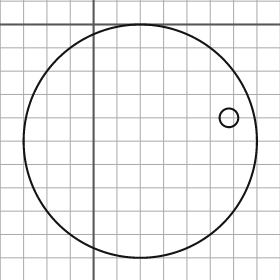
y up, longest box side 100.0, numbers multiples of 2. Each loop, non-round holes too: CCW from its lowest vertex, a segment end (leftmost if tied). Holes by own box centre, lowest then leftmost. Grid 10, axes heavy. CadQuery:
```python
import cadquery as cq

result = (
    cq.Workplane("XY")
    .moveTo(20.0, -50.0)
    .circle(50.0)
    .moveTo(58.0, -40.0)
    .circle(4.0)
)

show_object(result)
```